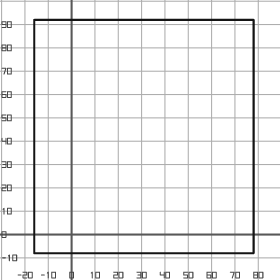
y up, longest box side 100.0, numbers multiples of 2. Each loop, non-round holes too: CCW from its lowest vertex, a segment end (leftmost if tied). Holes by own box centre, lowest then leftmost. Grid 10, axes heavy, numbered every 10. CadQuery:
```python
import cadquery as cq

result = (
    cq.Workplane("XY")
    .moveTo(-16.0, -8.0)
    .lineTo(78.0, -8.0)
    .lineTo(78.0, 92.0)
    .lineTo(-16.0, 92.0)
    .close()
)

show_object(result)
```